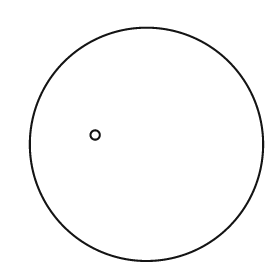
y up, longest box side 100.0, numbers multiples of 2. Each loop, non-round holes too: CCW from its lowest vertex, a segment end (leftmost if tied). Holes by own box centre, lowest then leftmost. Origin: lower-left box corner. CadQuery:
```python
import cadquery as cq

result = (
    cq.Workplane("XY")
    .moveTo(50.0, 50.0)
    .circle(50.0)
    .moveTo(28.0, 54.0)
    .circle(2.0)
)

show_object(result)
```